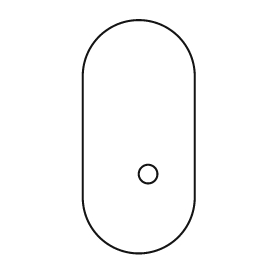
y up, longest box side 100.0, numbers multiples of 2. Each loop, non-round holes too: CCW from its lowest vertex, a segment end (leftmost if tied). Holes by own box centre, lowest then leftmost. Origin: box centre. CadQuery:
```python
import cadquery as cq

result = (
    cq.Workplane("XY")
    .moveTo(-24.0, -26.0)
    .threePointArc((0.0, -50.0), (24.0, -26.0))
    .lineTo(24.0, 26.0)
    .threePointArc((0.0, 50.0), (-24.0, 26.0))
    .close()
    .moveTo(4.0, -16.0)
    .circle(4.0)
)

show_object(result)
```